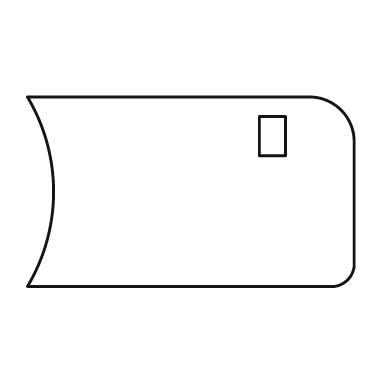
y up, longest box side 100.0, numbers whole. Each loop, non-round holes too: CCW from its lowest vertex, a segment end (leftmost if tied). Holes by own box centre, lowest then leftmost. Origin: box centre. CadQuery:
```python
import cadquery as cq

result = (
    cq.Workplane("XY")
    .moveTo(-50.0, -29.0)
    .lineTo(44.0, -29.0)
    .threePointArc((48.0, -27.0), (50.0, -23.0))
    .lineTo(50.0, 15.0)
    .threePointArc((46.0, 25.0), (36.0, 29.0))
    .lineTo(-50.0, 29.0)
    .threePointArc((-42.0, 0.0), (-50.0, -29.0))
    .close()
    .moveTo(21.0, 11.0)
    .lineTo(29.0, 11.0)
    .lineTo(29.0, 23.0)
    .lineTo(21.0, 23.0)
    .close()
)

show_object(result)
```